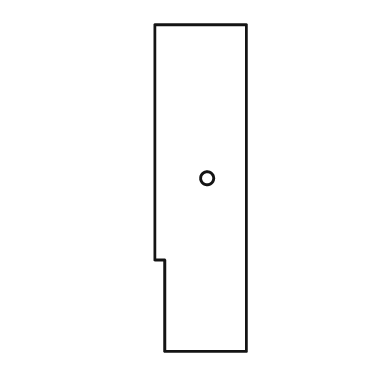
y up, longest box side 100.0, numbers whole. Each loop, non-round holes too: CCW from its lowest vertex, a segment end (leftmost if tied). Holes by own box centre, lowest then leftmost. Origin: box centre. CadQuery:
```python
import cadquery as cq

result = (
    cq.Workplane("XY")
    .moveTo(-11.0, -50.0)
    .lineTo(14.0, -50.0)
    .lineTo(14.0, 50.0)
    .lineTo(-14.0, 50.0)
    .lineTo(-14.0, -22.0)
    .lineTo(-11.0, -22.0)
    .close()
    .moveTo(2.0, 3.0)
    .circle(2.0)
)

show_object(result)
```